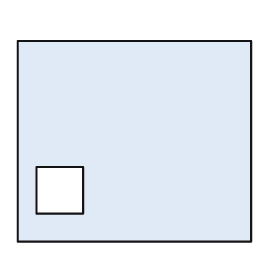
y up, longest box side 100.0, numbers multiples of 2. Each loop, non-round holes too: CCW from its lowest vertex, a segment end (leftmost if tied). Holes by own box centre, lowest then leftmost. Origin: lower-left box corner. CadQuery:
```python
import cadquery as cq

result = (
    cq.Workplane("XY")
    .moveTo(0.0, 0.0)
    .lineTo(100.0, 0.0)
    .lineTo(100.0, 86.0)
    .lineTo(0.0, 86.0)
    .close()
    .moveTo(8.0, 12.0)
    .lineTo(28.0, 12.0)
    .lineTo(28.0, 32.0)
    .lineTo(8.0, 32.0)
    .close()
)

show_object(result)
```